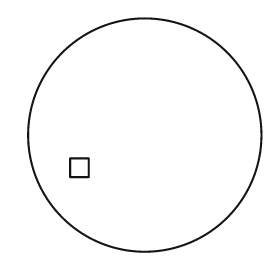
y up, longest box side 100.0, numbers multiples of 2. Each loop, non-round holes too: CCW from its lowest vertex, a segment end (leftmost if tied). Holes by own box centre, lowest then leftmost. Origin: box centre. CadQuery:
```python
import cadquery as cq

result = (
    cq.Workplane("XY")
    .moveTo(0.0, 0.0)
    .circle(50.0)
    .moveTo(-32.0, -18.0)
    .lineTo(-24.0, -18.0)
    .lineTo(-24.0, -10.0)
    .lineTo(-32.0, -10.0)
    .close()
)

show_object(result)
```